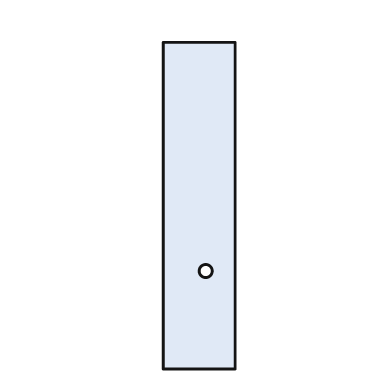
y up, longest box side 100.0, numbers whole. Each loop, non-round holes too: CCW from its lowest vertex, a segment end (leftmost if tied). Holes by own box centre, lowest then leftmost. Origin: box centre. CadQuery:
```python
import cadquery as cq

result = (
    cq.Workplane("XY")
    .moveTo(-11.0, -50.0)
    .lineTo(11.0, -50.0)
    .lineTo(11.0, 50.0)
    .lineTo(-11.0, 50.0)
    .close()
    .moveTo(2.0, -20.0)
    .circle(2.0)
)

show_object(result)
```